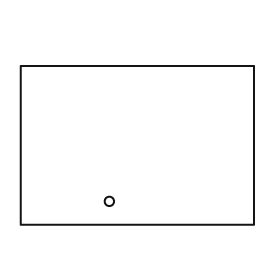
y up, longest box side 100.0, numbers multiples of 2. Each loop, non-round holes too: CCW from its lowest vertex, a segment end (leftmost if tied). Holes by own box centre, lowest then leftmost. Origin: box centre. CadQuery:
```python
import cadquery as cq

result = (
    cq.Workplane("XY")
    .moveTo(-50.0, -34.0)
    .lineTo(50.0, -34.0)
    .lineTo(50.0, 34.0)
    .lineTo(-50.0, 34.0)
    .close()
    .moveTo(-12.0, -24.0)
    .circle(2.0)
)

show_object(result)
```